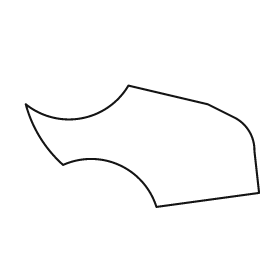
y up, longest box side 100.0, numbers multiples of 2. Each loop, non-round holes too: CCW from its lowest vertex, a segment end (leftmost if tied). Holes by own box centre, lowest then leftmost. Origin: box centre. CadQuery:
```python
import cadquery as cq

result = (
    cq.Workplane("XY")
    .moveTo(6.0, -26.0)
    .lineTo(50.0, -20.0)
    .lineTo(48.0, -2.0)
    .threePointArc((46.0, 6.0), (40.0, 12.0))
    .lineTo(28.0, 18.0)
    .lineTo(-6.0, 26.0)
    .threePointArc((-26.0, 12.0), (-50.0, 18.0))
    .threePointArc((-44.0, 4.0), (-34.0, -8.0))
    .threePointArc((-10.0, -8.0), (6.0, -26.0))
    .close()
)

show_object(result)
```